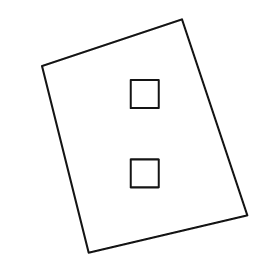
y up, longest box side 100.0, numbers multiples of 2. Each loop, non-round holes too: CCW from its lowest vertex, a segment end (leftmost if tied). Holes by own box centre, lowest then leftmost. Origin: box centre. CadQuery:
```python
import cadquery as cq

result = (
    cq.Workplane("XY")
    .moveTo(-24.0, -50.0)
    .lineTo(44.0, -34.0)
    .lineTo(16.0, 50.0)
    .lineTo(-44.0, 30.0)
    .close()
    .moveTo(-6.0, -22.0)
    .lineTo(6.0, -22.0)
    .lineTo(6.0, -10.0)
    .lineTo(-6.0, -10.0)
    .close()
    .moveTo(-6.0, 12.0)
    .lineTo(6.0, 12.0)
    .lineTo(6.0, 24.0)
    .lineTo(-6.0, 24.0)
    .close()
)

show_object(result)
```